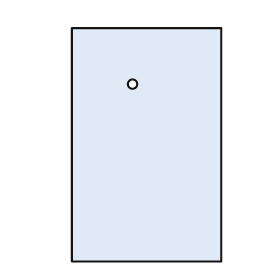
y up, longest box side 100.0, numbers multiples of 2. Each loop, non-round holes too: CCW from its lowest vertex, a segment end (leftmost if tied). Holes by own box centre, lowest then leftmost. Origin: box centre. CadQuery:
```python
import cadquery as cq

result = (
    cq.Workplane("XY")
    .moveTo(-32.0, -50.0)
    .lineTo(32.0, -50.0)
    .lineTo(32.0, 50.0)
    .lineTo(-32.0, 50.0)
    .close()
    .moveTo(-6.0, 26.0)
    .circle(2.0)
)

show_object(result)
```